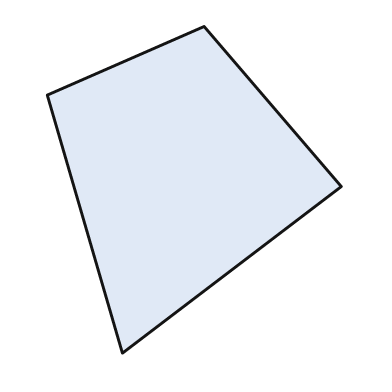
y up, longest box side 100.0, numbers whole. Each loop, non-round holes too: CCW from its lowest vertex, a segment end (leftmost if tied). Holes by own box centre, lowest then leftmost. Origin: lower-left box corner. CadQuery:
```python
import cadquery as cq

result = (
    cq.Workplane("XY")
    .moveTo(23.0, 0.0)
    .lineTo(90.0, 51.0)
    .lineTo(48.0, 100.0)
    .lineTo(0.0, 79.0)
    .close()
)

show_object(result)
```